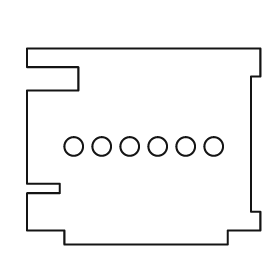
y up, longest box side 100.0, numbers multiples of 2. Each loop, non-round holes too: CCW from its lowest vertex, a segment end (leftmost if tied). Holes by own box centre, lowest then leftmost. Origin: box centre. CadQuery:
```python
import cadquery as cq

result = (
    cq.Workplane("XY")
    .moveTo(-34.0, -42.0)
    .lineTo(36.0, -42.0)
    .lineTo(36.0, -36.0)
    .lineTo(50.0, -36.0)
    .lineTo(50.0, -28.0)
    .lineTo(46.0, -28.0)
    .lineTo(46.0, 30.0)
    .lineTo(50.0, 30.0)
    .lineTo(50.0, 42.0)
    .lineTo(-50.0, 42.0)
    .lineTo(-50.0, 34.0)
    .lineTo(-28.0, 34.0)
    .lineTo(-28.0, 24.0)
    .lineTo(-50.0, 24.0)
    .lineTo(-50.0, -16.0)
    .lineTo(-36.0, -16.0)
    .lineTo(-36.0, -20.0)
    .lineTo(-50.0, -20.0)
    .lineTo(-50.0, -36.0)
    .lineTo(-34.0, -36.0)
    .close()
    .moveTo(-30.0, 0.0)
    .circle(4.0)
    .moveTo(-18.0, 0.0)
    .circle(4.0)
    .moveTo(-6.0, 0.0)
    .circle(4.0)
    .moveTo(6.0, 0.0)
    .circle(4.0)
    .moveTo(18.0, 0.0)
    .circle(4.0)
    .moveTo(30.0, 0.0)
    .circle(4.0)
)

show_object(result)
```